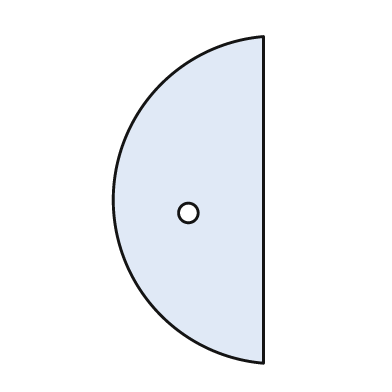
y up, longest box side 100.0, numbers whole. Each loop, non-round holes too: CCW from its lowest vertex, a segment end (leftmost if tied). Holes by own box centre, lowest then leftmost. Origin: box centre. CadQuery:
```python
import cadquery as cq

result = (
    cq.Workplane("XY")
    .moveTo(23.0, -50.0)
    .lineTo(23.0, 50.0)
    .threePointArc((-23.0, 0.0), (23.0, -50.0))
    .close()
    .moveTo(0.0, -4.0)
    .circle(3.0)
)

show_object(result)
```